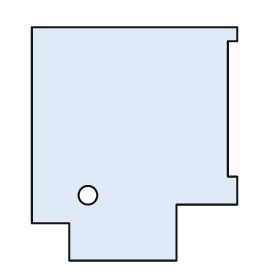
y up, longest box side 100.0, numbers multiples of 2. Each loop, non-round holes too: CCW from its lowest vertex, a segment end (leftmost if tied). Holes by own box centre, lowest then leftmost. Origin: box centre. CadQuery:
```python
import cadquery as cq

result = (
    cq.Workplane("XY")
    .moveTo(-28.0, -50.0)
    .lineTo(18.0, -50.0)
    .lineTo(18.0, -26.0)
    .lineTo(44.0, -26.0)
    .lineTo(44.0, -14.0)
    .lineTo(40.0, -14.0)
    .lineTo(40.0, 44.0)
    .lineTo(44.0, 44.0)
    .lineTo(44.0, 50.0)
    .lineTo(-44.0, 50.0)
    .lineTo(-44.0, -34.0)
    .lineTo(-28.0, -34.0)
    .close()
    .moveTo(-20.0, -22.0)
    .circle(4.0)
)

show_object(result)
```